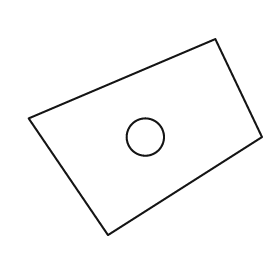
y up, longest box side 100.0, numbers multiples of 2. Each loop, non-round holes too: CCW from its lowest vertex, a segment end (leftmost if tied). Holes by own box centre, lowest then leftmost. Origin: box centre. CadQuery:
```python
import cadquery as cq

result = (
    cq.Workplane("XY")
    .moveTo(-16.0, -42.0)
    .lineTo(50.0, 0.0)
    .lineTo(30.0, 42.0)
    .lineTo(-50.0, 8.0)
    .close()
    .moveTo(0.0, 0.0)
    .circle(8.0)
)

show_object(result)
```